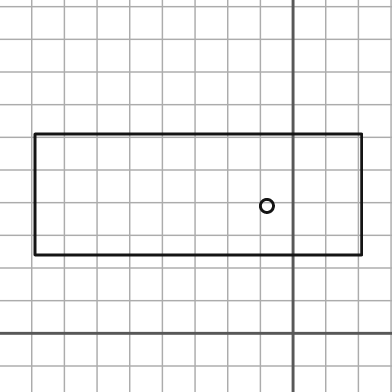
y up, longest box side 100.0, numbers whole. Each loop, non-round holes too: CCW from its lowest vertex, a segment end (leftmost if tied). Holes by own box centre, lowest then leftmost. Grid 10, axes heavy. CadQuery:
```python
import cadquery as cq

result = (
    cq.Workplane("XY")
    .moveTo(-79.0, 24.0)
    .lineTo(21.0, 24.0)
    .lineTo(21.0, 61.0)
    .lineTo(-79.0, 61.0)
    .close()
    .moveTo(-8.0, 39.0)
    .circle(2.0)
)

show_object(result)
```